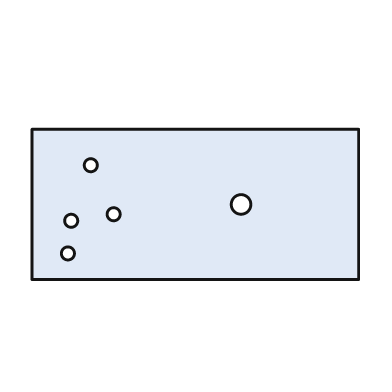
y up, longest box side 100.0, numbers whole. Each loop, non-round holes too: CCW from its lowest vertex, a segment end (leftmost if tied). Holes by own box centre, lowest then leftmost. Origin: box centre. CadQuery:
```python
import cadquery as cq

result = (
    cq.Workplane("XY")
    .moveTo(-50.0, -23.0)
    .lineTo(50.0, -23.0)
    .lineTo(50.0, 23.0)
    .lineTo(-50.0, 23.0)
    .close()
    .moveTo(-39.0, -15.0)
    .circle(2.0)
    .moveTo(-38.0, -5.0)
    .circle(2.0)
    .moveTo(-25.0, -3.0)
    .circle(2.0)
    .moveTo(14.0, 0.0)
    .circle(3.0)
    .moveTo(-32.0, 12.0)
    .circle(2.0)
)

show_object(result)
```